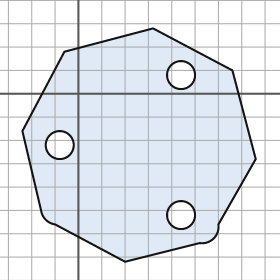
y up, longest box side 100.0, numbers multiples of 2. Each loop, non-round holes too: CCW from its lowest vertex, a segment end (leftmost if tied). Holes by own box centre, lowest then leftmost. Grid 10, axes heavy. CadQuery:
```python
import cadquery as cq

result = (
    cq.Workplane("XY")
    .moveTo(20.0, -72.0)
    .lineTo(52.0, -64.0)
    .threePointArc((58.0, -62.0), (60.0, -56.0))
    .lineTo(76.0, -28.0)
    .lineTo(66.0, 10.0)
    .lineTo(32.0, 28.0)
    .lineTo(-6.0, 18.0)
    .lineTo(-24.0, -16.0)
    .lineTo(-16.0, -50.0)
    .threePointArc((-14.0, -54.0), (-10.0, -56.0))
    .close()
    .moveTo(44.0, -52.0)
    .circle(6.0)
    .moveTo(-8.0, -22.0)
    .circle(6.0)
    .moveTo(44.0, 8.0)
    .circle(6.0)
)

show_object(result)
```